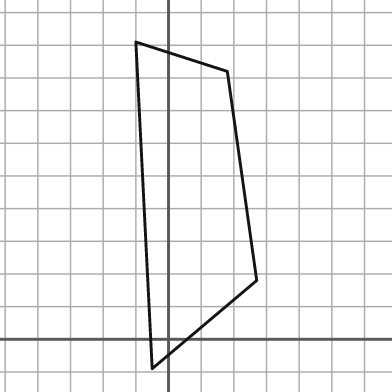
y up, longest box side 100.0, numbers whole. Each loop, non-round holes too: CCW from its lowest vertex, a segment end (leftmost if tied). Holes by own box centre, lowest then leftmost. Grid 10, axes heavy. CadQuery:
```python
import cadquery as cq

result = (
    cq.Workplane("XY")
    .moveTo(-5.0, -9.0)
    .lineTo(27.0, 18.0)
    .lineTo(18.0, 82.0)
    .lineTo(-10.0, 91.0)
    .close()
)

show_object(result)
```